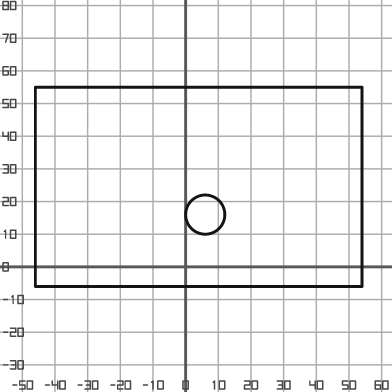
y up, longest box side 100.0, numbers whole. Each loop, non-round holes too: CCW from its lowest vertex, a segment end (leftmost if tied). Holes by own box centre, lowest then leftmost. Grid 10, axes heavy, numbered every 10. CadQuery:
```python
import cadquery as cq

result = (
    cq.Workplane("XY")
    .moveTo(-46.0, -6.0)
    .lineTo(54.0, -6.0)
    .lineTo(54.0, 55.0)
    .lineTo(-46.0, 55.0)
    .close()
    .moveTo(6.0, 16.0)
    .circle(6.0)
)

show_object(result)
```